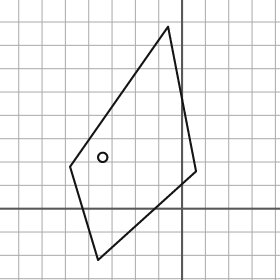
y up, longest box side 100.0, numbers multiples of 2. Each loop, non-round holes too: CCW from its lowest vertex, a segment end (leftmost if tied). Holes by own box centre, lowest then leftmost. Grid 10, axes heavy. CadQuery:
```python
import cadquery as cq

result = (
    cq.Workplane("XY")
    .moveTo(-36.0, -22.0)
    .lineTo(6.0, 16.0)
    .lineTo(-6.0, 78.0)
    .lineTo(-48.0, 18.0)
    .close()
    .moveTo(-34.0, 22.0)
    .circle(2.0)
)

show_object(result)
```